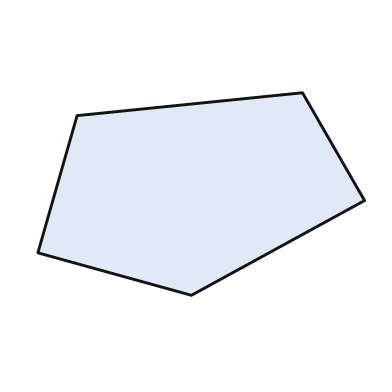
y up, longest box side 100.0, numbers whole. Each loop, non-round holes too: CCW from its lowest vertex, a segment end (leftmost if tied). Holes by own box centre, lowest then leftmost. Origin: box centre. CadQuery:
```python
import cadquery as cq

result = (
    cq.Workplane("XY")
    .moveTo(-3.0, -31.0)
    .lineTo(50.0, -2.0)
    .lineTo(31.0, 31.0)
    .lineTo(-38.0, 24.0)
    .lineTo(-50.0, -18.0)
    .close()
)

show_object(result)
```